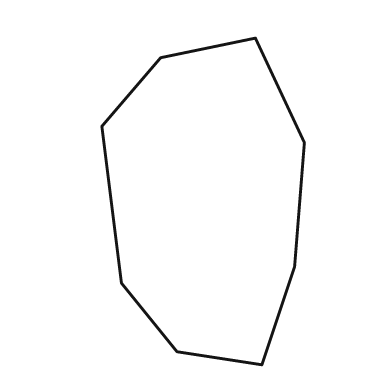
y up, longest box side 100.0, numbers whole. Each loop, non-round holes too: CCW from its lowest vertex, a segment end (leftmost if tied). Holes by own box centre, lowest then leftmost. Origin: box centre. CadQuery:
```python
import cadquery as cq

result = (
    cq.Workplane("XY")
    .moveTo(18.0, -50.0)
    .lineTo(28.0, -20.0)
    .lineTo(31.0, 18.0)
    .lineTo(16.0, 50.0)
    .lineTo(-13.0, 44.0)
    .lineTo(-31.0, 23.0)
    .lineTo(-25.0, -25.0)
    .lineTo(-8.0, -46.0)
    .close()
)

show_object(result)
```